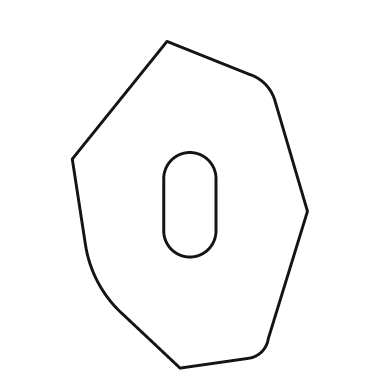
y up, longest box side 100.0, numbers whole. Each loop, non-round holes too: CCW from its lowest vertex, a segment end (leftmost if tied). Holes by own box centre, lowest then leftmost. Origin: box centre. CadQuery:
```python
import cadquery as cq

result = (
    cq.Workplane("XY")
    .moveTo(-3.0, -50.0)
    .lineTo(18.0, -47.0)
    .threePointArc((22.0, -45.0), (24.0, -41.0))
    .lineTo(36.0, -2.0)
    .lineTo(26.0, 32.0)
    .threePointArc((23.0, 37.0), (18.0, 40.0))
    .lineTo(-7.0, 50.0)
    .lineTo(-36.0, 14.0)
    .lineTo(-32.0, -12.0)
    .threePointArc((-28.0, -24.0), (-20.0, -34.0))
    .close()
    .moveTo(-8.0, -8.0)
    .threePointArc((0.0, -16.0), (8.0, -8.0))
    .lineTo(8.0, 8.0)
    .threePointArc((0.0, 16.0), (-8.0, 8.0))
    .close()
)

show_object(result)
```